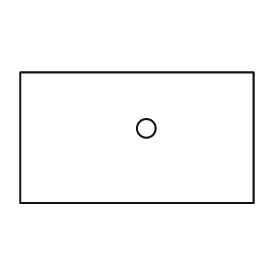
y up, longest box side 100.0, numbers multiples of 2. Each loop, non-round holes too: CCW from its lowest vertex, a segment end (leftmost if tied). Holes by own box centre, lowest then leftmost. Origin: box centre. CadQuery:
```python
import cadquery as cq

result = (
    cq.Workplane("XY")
    .moveTo(-50.0, -28.0)
    .lineTo(50.0, -28.0)
    .lineTo(50.0, 28.0)
    .lineTo(-50.0, 28.0)
    .close()
    .moveTo(4.0, 4.0)
    .circle(4.0)
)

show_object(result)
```